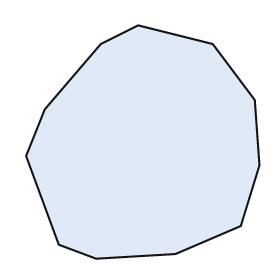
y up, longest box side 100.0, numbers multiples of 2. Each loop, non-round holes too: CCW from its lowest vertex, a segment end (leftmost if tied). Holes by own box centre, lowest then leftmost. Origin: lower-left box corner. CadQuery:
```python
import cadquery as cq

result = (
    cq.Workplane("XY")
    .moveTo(30.0, 0.0)
    .lineTo(64.0, 2.0)
    .lineTo(92.0, 14.0)
    .lineTo(100.0, 40.0)
    .lineTo(98.0, 68.0)
    .lineTo(80.0, 92.0)
    .lineTo(48.0, 100.0)
    .lineTo(32.0, 92.0)
    .lineTo(8.0, 64.0)
    .lineTo(0.0, 44.0)
    .lineTo(14.0, 6.0)
    .close()
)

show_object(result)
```